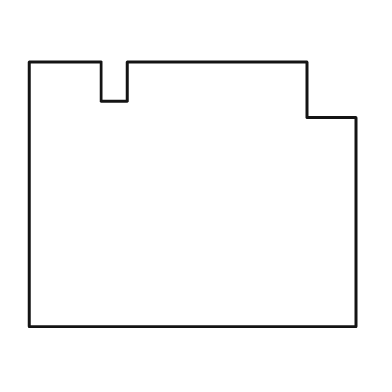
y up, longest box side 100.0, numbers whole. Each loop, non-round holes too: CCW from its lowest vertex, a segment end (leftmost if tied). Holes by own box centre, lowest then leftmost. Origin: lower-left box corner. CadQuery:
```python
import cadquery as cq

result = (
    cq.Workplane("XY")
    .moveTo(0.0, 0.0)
    .lineTo(100.0, 0.0)
    .lineTo(100.0, 64.0)
    .lineTo(85.0, 64.0)
    .lineTo(85.0, 81.0)
    .lineTo(30.0, 81.0)
    .lineTo(30.0, 69.0)
    .lineTo(22.0, 69.0)
    .lineTo(22.0, 81.0)
    .lineTo(0.0, 81.0)
    .close()
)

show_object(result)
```